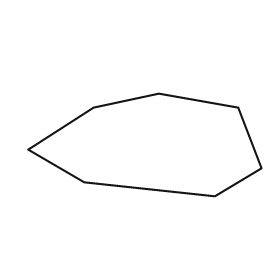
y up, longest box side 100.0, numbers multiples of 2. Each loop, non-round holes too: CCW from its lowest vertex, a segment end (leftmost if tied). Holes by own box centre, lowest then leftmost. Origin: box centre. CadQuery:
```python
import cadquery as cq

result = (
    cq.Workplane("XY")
    .moveTo(30.0, -22.0)
    .lineTo(50.0, -10.0)
    .lineTo(40.0, 16.0)
    .lineTo(6.0, 22.0)
    .lineTo(-22.0, 16.0)
    .lineTo(-50.0, -2.0)
    .lineTo(-26.0, -16.0)
    .close()
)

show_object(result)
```